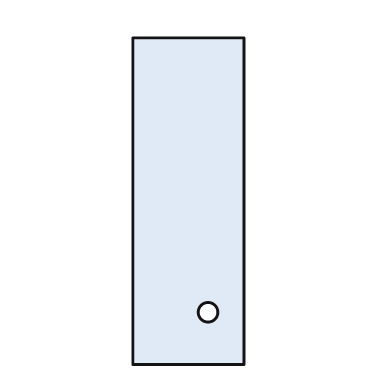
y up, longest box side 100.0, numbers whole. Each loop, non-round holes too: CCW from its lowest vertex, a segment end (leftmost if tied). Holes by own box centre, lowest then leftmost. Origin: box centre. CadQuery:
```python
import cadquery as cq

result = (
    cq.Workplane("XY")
    .moveTo(-17.0, -50.0)
    .lineTo(17.0, -50.0)
    .lineTo(17.0, 50.0)
    .lineTo(-17.0, 50.0)
    .close()
    .moveTo(6.0, -34.0)
    .circle(3.0)
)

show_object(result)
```